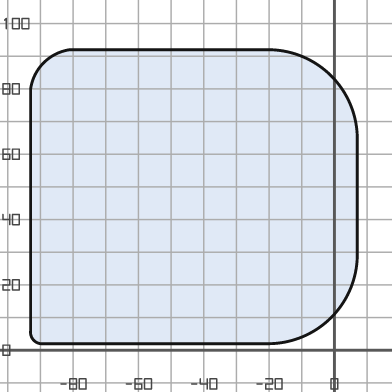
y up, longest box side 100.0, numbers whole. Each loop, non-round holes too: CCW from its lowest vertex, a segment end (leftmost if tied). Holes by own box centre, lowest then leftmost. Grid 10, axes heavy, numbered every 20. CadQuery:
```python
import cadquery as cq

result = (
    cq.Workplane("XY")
    .moveTo(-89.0, 2.0)
    .lineTo(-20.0, 2.0)
    .threePointArc((-1.0, 10.0), (7.0, 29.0))
    .lineTo(7.0, 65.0)
    .threePointArc((-1.0, 84.0), (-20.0, 92.0))
    .lineTo(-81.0, 92.0)
    .threePointArc((-89.0, 88.0), (-93.0, 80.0))
    .lineTo(-93.0, 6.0)
    .threePointArc((-92.0, 3.0), (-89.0, 2.0))
    .close()
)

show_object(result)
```